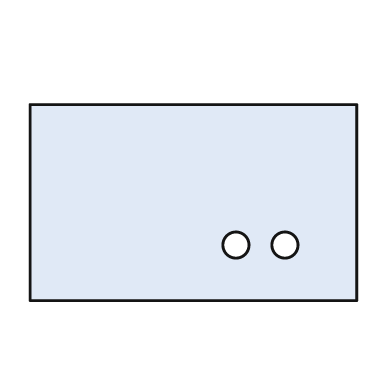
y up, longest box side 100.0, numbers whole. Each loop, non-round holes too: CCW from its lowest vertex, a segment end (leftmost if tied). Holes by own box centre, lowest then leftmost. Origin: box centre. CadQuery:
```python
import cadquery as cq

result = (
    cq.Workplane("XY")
    .moveTo(-50.0, -30.0)
    .lineTo(50.0, -30.0)
    .lineTo(50.0, 30.0)
    .lineTo(-50.0, 30.0)
    .close()
    .moveTo(13.0, -13.0)
    .circle(4.0)
    .moveTo(28.0, -13.0)
    .circle(4.0)
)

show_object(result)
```